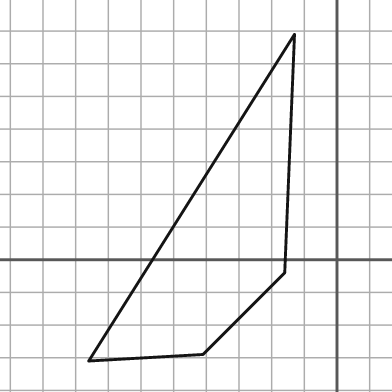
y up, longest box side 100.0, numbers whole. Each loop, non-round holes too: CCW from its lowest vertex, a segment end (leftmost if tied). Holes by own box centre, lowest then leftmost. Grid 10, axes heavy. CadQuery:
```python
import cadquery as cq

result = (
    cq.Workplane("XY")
    .moveTo(-76.0, -31.0)
    .lineTo(-41.0, -29.0)
    .lineTo(-16.0, -4.0)
    .lineTo(-13.0, 69.0)
    .close()
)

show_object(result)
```